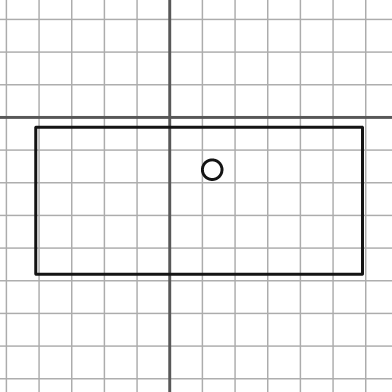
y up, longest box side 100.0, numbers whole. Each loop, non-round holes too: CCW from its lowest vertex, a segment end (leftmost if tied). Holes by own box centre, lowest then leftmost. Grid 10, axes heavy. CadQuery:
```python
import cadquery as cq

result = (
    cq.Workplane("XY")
    .moveTo(-41.0, -48.0)
    .lineTo(59.0, -48.0)
    .lineTo(59.0, -3.0)
    .lineTo(-41.0, -3.0)
    .close()
    .moveTo(13.0, -16.0)
    .circle(3.0)
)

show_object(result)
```